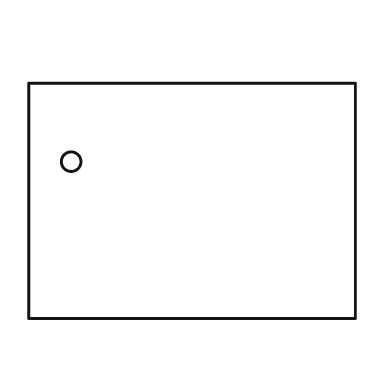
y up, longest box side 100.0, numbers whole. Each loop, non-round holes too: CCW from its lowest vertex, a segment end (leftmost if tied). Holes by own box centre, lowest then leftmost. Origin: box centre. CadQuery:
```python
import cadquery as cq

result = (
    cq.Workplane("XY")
    .moveTo(-50.0, -36.0)
    .lineTo(50.0, -36.0)
    .lineTo(50.0, 36.0)
    .lineTo(-50.0, 36.0)
    .close()
    .moveTo(-37.0, 12.0)
    .circle(3.0)
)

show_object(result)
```